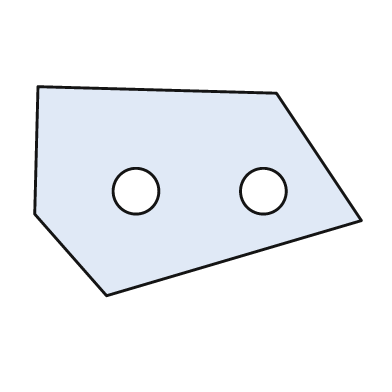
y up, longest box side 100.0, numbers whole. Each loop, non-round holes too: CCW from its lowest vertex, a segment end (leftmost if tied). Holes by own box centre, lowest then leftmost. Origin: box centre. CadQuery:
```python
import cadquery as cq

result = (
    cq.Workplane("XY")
    .moveTo(-28.0, -32.0)
    .lineTo(50.0, -9.0)
    .lineTo(24.0, 30.0)
    .lineTo(-49.0, 32.0)
    .lineTo(-50.0, -7.0)
    .close()
    .moveTo(-19.0, 0.0)
    .circle(7.0)
    .moveTo(20.0, 0.0)
    .circle(7.0)
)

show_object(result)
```